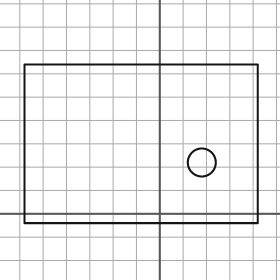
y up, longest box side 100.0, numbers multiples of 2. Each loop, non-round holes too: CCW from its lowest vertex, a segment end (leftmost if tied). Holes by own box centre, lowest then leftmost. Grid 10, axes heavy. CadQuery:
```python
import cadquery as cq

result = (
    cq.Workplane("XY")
    .moveTo(-58.0, -4.0)
    .lineTo(42.0, -4.0)
    .lineTo(42.0, 64.0)
    .lineTo(-58.0, 64.0)
    .close()
    .moveTo(18.0, 22.0)
    .circle(6.0)
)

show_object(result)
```